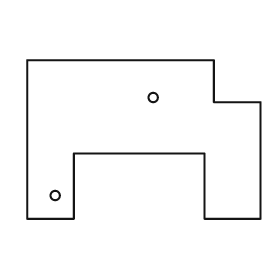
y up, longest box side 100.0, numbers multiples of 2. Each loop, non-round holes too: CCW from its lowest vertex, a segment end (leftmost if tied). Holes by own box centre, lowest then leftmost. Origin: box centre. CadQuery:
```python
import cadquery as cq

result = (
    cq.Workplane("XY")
    .moveTo(-50.0, -34.0)
    .lineTo(-30.0, -34.0)
    .lineTo(-30.0, -6.0)
    .lineTo(26.0, -6.0)
    .lineTo(26.0, -34.0)
    .lineTo(50.0, -34.0)
    .lineTo(50.0, 16.0)
    .lineTo(30.0, 16.0)
    .lineTo(30.0, 34.0)
    .lineTo(-50.0, 34.0)
    .close()
    .moveTo(-38.0, -24.0)
    .circle(2.0)
    .moveTo(4.0, 18.0)
    .circle(2.0)
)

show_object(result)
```